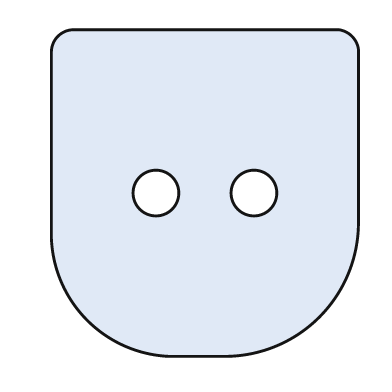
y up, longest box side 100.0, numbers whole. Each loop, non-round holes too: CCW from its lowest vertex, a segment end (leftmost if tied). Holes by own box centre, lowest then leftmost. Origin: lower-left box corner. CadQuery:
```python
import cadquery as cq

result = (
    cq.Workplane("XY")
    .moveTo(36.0, 0.0)
    .lineTo(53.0, 0.0)
    .threePointArc((82.0, 12.0), (94.0, 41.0))
    .lineTo(94.0, 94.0)
    .threePointArc((92.0, 98.0), (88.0, 100.0))
    .lineTo(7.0, 100.0)
    .threePointArc((2.0, 98.0), (0.0, 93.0))
    .lineTo(0.0, 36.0)
    .threePointArc((11.0, 11.0), (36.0, 0.0))
    .close()
    .moveTo(32.0, 50.0)
    .circle(7.0)
    .moveTo(62.0, 50.0)
    .circle(7.0)
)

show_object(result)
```